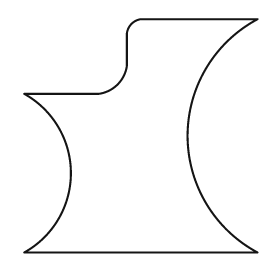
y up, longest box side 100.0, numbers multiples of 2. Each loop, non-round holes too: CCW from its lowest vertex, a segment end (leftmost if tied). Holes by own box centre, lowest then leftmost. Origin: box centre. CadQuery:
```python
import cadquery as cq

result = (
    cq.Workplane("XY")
    .moveTo(-50.0, -50.0)
    .lineTo(50.0, -50.0)
    .threePointArc((20.0, 0.0), (50.0, 50.0))
    .lineTo(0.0, 50.0)
    .threePointArc((-4.0, 48.0), (-6.0, 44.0))
    .lineTo(-6.0, 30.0)
    .threePointArc((-10.0, 22.0), (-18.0, 18.0))
    .lineTo(-50.0, 18.0)
    .threePointArc((-30.0, -16.0), (-50.0, -50.0))
    .close()
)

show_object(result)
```